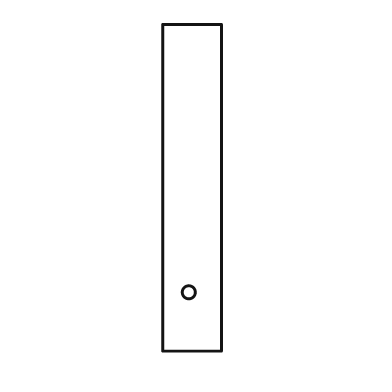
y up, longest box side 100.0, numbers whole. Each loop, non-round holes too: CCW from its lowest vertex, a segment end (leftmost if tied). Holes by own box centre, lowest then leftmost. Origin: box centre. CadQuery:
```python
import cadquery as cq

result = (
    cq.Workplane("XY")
    .moveTo(-9.0, -50.0)
    .lineTo(9.0, -50.0)
    .lineTo(9.0, 50.0)
    .lineTo(-9.0, 50.0)
    .close()
    .moveTo(-1.0, -32.0)
    .circle(2.0)
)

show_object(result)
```